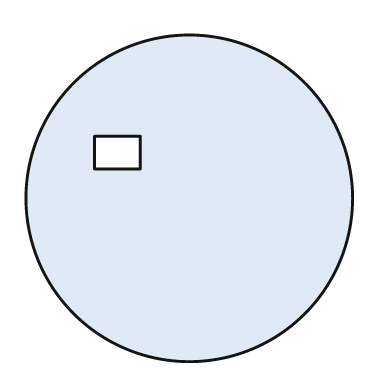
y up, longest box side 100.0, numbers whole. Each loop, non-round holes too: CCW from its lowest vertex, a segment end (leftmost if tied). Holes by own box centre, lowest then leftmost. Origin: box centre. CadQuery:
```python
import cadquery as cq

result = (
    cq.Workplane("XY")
    .moveTo(0.0, 0.0)
    .circle(50.0)
    .moveTo(-29.0, 9.0)
    .lineTo(-15.0, 9.0)
    .lineTo(-15.0, 19.0)
    .lineTo(-29.0, 19.0)
    .close()
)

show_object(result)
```